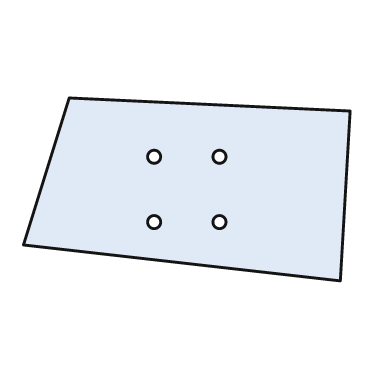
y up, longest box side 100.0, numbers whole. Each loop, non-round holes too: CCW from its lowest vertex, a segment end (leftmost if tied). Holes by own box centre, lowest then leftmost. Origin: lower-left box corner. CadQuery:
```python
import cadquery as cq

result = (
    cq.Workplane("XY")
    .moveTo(97.0, 0.0)
    .lineTo(100.0, 52.0)
    .lineTo(14.0, 56.0)
    .lineTo(0.0, 11.0)
    .close()
    .moveTo(40.0, 18.0)
    .circle(2.0)
    .moveTo(60.0, 18.0)
    .circle(2.0)
    .moveTo(40.0, 38.0)
    .circle(2.0)
    .moveTo(60.0, 38.0)
    .circle(2.0)
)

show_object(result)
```